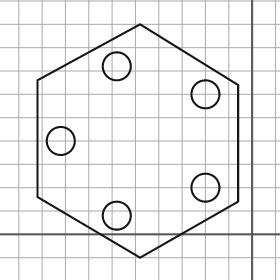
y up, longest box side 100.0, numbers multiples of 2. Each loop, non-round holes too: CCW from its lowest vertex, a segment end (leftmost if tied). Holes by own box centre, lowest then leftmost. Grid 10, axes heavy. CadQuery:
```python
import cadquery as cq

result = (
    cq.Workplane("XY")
    .moveTo(-48.0, -10.0)
    .lineTo(-6.0, 14.0)
    .lineTo(-6.0, 64.0)
    .lineTo(-48.0, 90.0)
    .lineTo(-92.0, 66.0)
    .lineTo(-92.0, 16.0)
    .close()
    .moveTo(-58.0, 8.0)
    .circle(6.0)
    .moveTo(-20.0, 20.0)
    .circle(6.0)
    .moveTo(-82.0, 40.0)
    .circle(6.0)
    .moveTo(-20.0, 60.0)
    .circle(6.0)
    .moveTo(-58.0, 72.0)
    .circle(6.0)
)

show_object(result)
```